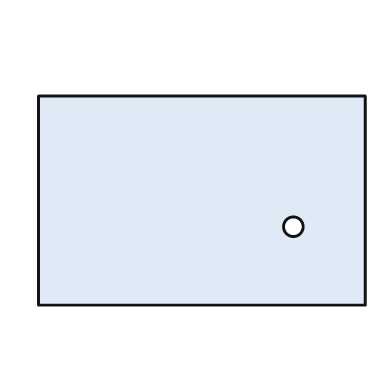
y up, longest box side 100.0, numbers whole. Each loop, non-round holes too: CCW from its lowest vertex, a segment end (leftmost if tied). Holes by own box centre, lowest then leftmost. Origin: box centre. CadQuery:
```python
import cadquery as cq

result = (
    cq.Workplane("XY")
    .moveTo(-50.0, -32.0)
    .lineTo(50.0, -32.0)
    .lineTo(50.0, 32.0)
    .lineTo(-50.0, 32.0)
    .close()
    .moveTo(28.0, -8.0)
    .circle(3.0)
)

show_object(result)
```